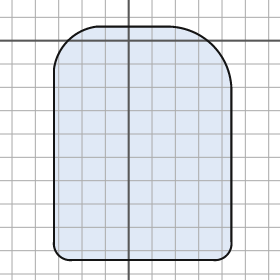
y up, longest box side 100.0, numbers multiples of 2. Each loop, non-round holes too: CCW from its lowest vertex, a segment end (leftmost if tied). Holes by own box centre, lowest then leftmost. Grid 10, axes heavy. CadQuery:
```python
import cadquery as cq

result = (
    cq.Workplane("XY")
    .moveTo(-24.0, -94.0)
    .lineTo(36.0, -94.0)
    .threePointArc((42.0, -92.0), (44.0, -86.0))
    .lineTo(44.0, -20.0)
    .threePointArc((36.0, -2.0), (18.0, 6.0))
    .lineTo(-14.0, 6.0)
    .threePointArc((-26.0, 0.0), (-32.0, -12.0))
    .lineTo(-32.0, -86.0)
    .threePointArc((-30.0, -92.0), (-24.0, -94.0))
    .close()
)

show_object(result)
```